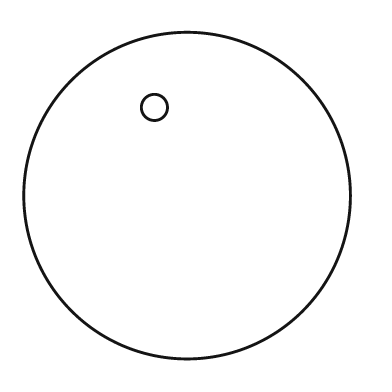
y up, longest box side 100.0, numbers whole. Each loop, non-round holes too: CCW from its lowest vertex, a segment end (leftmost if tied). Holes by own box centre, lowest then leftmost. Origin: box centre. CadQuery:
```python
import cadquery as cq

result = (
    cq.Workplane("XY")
    .moveTo(0.0, 0.0)
    .circle(50.0)
    .moveTo(-10.0, 27.0)
    .circle(4.0)
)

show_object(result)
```